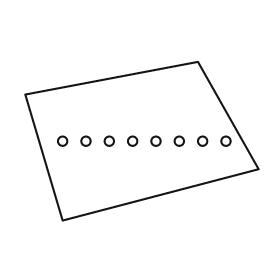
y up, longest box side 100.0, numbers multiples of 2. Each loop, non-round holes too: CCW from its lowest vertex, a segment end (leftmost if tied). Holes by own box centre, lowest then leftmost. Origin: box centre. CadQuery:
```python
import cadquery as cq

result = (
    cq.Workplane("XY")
    .moveTo(-34.0, -34.0)
    .lineTo(50.0, -12.0)
    .lineTo(24.0, 34.0)
    .lineTo(-50.0, 20.0)
    .close()
    .moveTo(-34.0, 0.0)
    .circle(2.0)
    .moveTo(-24.0, 0.0)
    .circle(2.0)
    .moveTo(-14.0, 0.0)
    .circle(2.0)
    .moveTo(-4.0, 0.0)
    .circle(2.0)
    .moveTo(6.0, 0.0)
    .circle(2.0)
    .moveTo(16.0, 0.0)
    .circle(2.0)
    .moveTo(26.0, 0.0)
    .circle(2.0)
    .moveTo(36.0, 0.0)
    .circle(2.0)
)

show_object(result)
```